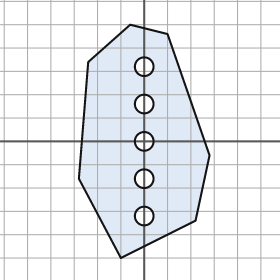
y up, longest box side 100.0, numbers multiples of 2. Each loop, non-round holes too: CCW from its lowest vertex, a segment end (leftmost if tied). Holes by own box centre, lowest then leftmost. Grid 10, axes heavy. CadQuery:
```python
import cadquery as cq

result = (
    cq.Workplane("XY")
    .moveTo(-10.0, -50.0)
    .lineTo(22.0, -34.0)
    .lineTo(28.0, -6.0)
    .lineTo(10.0, 46.0)
    .lineTo(-6.0, 50.0)
    .lineTo(-24.0, 34.0)
    .lineTo(-28.0, -16.0)
    .close()
    .moveTo(0.0, -32.0)
    .circle(4.0)
    .moveTo(0.0, -16.0)
    .circle(4.0)
    .moveTo(0.0, 0.0)
    .circle(4.0)
    .moveTo(0.0, 16.0)
    .circle(4.0)
    .moveTo(0.0, 32.0)
    .circle(4.0)
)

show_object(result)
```